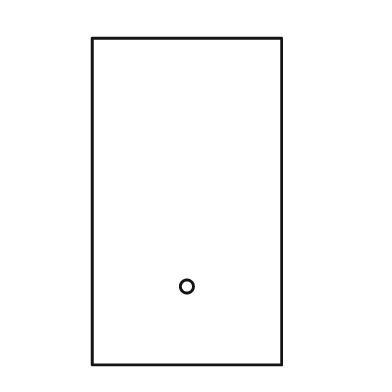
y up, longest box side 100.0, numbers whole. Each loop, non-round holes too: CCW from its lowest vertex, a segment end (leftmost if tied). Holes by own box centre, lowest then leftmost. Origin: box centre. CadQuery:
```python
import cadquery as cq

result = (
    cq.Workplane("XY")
    .moveTo(-29.0, -50.0)
    .lineTo(29.0, -50.0)
    .lineTo(29.0, 50.0)
    .lineTo(-29.0, 50.0)
    .close()
    .moveTo(0.0, -26.0)
    .circle(2.0)
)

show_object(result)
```